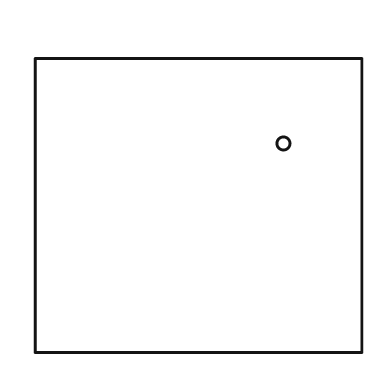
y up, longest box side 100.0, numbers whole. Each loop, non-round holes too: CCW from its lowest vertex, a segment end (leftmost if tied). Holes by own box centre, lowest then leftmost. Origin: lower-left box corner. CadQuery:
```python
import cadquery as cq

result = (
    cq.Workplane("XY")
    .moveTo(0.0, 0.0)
    .lineTo(100.0, 0.0)
    .lineTo(100.0, 90.0)
    .lineTo(0.0, 90.0)
    .close()
    .moveTo(76.0, 64.0)
    .circle(2.0)
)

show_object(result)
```